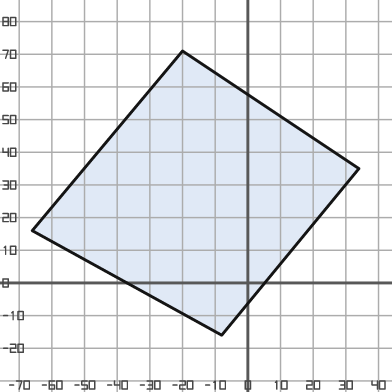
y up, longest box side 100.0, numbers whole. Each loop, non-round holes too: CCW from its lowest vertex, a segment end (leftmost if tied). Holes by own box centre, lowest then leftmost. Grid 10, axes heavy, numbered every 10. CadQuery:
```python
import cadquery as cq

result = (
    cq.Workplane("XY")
    .moveTo(-8.0, -16.0)
    .lineTo(34.0, 35.0)
    .lineTo(-20.0, 71.0)
    .lineTo(-66.0, 16.0)
    .close()
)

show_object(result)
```